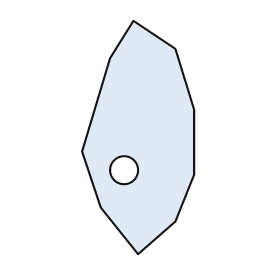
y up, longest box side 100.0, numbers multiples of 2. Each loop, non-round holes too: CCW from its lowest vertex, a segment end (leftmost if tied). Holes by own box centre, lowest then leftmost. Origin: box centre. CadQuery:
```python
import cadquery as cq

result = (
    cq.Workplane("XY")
    .moveTo(0.0, -50.0)
    .lineTo(16.0, -36.0)
    .lineTo(24.0, -16.0)
    .lineTo(24.0, 12.0)
    .lineTo(16.0, 38.0)
    .lineTo(-2.0, 50.0)
    .lineTo(-12.0, 34.0)
    .lineTo(-24.0, -6.0)
    .lineTo(-16.0, -30.0)
    .close()
    .moveTo(-6.0, -14.0)
    .circle(6.0)
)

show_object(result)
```